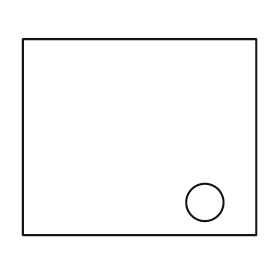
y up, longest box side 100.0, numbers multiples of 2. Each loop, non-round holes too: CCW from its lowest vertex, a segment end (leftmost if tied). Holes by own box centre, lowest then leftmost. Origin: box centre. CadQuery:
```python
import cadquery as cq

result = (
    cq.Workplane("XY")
    .moveTo(-50.0, -42.0)
    .lineTo(50.0, -42.0)
    .lineTo(50.0, 42.0)
    .lineTo(-50.0, 42.0)
    .close()
    .moveTo(28.0, -28.0)
    .circle(8.0)
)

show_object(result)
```